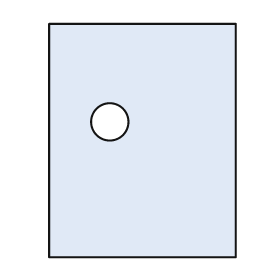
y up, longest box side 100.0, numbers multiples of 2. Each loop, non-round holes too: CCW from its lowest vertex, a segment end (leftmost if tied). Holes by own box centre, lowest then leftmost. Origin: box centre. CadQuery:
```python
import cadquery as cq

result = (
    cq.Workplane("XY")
    .moveTo(-40.0, -50.0)
    .lineTo(40.0, -50.0)
    .lineTo(40.0, 50.0)
    .lineTo(-40.0, 50.0)
    .close()
    .moveTo(-14.0, 8.0)
    .circle(8.0)
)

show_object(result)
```